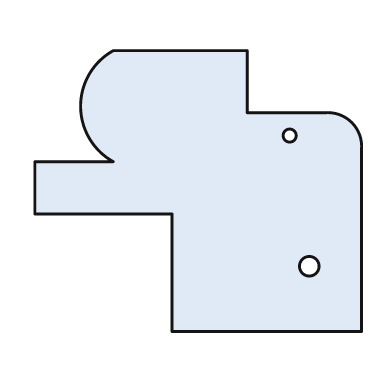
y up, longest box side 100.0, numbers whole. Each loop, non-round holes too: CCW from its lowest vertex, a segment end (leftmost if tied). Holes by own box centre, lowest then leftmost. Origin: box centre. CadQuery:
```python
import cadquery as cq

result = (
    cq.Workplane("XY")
    .moveTo(-8.0, -43.0)
    .lineTo(50.0, -43.0)
    .lineTo(50.0, 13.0)
    .threePointArc((47.0, 21.0), (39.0, 24.0))
    .lineTo(15.0, 24.0)
    .lineTo(15.0, 43.0)
    .lineTo(-26.0, 43.0)
    .threePointArc((-36.0, 26.0), (-26.0, 9.0))
    .lineTo(-50.0, 9.0)
    .lineTo(-50.0, -7.0)
    .lineTo(-8.0, -7.0)
    .close()
    .moveTo(34.0, -23.0)
    .circle(3.0)
    .moveTo(28.0, 17.0)
    .circle(2.0)
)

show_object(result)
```